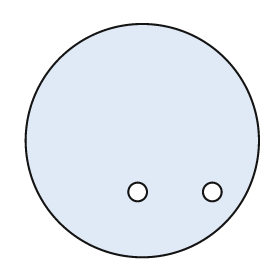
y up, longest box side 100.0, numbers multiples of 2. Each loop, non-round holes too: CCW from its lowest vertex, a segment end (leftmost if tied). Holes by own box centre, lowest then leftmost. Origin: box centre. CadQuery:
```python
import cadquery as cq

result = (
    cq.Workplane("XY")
    .moveTo(0.0, 0.0)
    .circle(50.0)
    .moveTo(-2.0, -22.0)
    .circle(4.0)
    .moveTo(30.0, -22.0)
    .circle(4.0)
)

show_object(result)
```